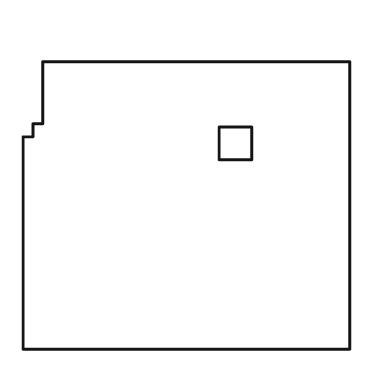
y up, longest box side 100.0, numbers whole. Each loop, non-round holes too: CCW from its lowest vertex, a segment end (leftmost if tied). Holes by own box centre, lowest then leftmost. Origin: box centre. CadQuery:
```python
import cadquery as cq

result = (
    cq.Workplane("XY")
    .moveTo(-50.0, -44.0)
    .lineTo(50.0, -44.0)
    .lineTo(50.0, 44.0)
    .lineTo(-44.0, 44.0)
    .lineTo(-44.0, 25.0)
    .lineTo(-47.0, 25.0)
    .lineTo(-47.0, 21.0)
    .lineTo(-50.0, 21.0)
    .close()
    .moveTo(10.0, 14.0)
    .lineTo(20.0, 14.0)
    .lineTo(20.0, 24.0)
    .lineTo(10.0, 24.0)
    .close()
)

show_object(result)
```